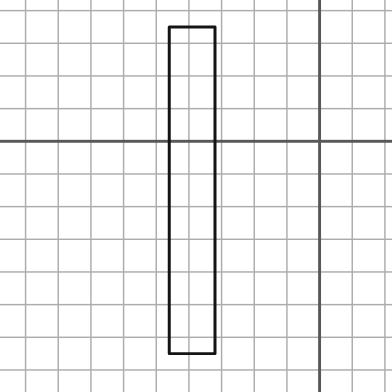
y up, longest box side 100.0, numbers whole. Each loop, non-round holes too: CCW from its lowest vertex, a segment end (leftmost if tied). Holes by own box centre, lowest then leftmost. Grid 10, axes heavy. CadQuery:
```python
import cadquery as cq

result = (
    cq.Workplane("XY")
    .moveTo(-46.0, -65.0)
    .lineTo(-32.0, -65.0)
    .lineTo(-32.0, 35.0)
    .lineTo(-46.0, 35.0)
    .close()
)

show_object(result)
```